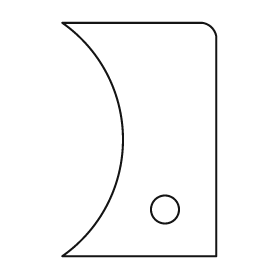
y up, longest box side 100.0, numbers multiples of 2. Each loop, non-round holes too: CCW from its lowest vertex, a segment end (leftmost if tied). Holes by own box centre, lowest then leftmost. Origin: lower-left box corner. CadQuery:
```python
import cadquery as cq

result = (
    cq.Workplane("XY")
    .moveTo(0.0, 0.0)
    .lineTo(66.0, 0.0)
    .lineTo(66.0, 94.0)
    .threePointArc((64.0, 98.0), (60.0, 100.0))
    .lineTo(0.0, 100.0)
    .threePointArc((26.0, 50.0), (0.0, 0.0))
    .close()
    .moveTo(44.0, 20.0)
    .circle(6.0)
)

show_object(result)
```